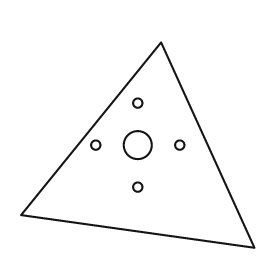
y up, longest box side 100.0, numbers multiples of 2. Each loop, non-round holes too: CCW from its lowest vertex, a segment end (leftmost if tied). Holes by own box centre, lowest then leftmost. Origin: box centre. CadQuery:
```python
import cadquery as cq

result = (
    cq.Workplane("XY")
    .moveTo(50.0, -44.0)
    .lineTo(10.0, 44.0)
    .lineTo(-50.0, -30.0)
    .close()
    .moveTo(0.0, -18.0)
    .circle(2.0)
    .moveTo(-18.0, 0.0)
    .circle(2.0)
    .moveTo(0.0, 0.0)
    .circle(6.0)
    .moveTo(18.0, 0.0)
    .circle(2.0)
    .moveTo(0.0, 18.0)
    .circle(2.0)
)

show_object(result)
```